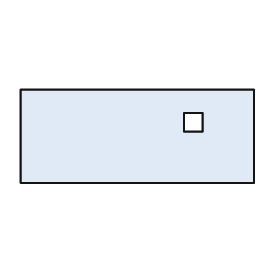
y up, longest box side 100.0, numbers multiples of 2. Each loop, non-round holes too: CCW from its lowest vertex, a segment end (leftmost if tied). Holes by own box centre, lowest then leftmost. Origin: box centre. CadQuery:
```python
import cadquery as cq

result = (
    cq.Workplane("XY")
    .moveTo(-50.0, -20.0)
    .lineTo(50.0, -20.0)
    .lineTo(50.0, 20.0)
    .lineTo(-50.0, 20.0)
    .close()
    .moveTo(20.0, 2.0)
    .lineTo(28.0, 2.0)
    .lineTo(28.0, 10.0)
    .lineTo(20.0, 10.0)
    .close()
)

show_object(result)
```